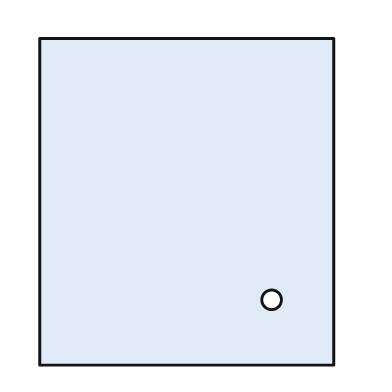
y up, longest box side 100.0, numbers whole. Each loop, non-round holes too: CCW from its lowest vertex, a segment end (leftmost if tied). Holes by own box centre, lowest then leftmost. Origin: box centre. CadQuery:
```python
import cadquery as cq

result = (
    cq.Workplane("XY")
    .moveTo(-45.0, -50.0)
    .lineTo(45.0, -50.0)
    .lineTo(45.0, 50.0)
    .lineTo(-45.0, 50.0)
    .close()
    .moveTo(26.0, -30.0)
    .circle(3.0)
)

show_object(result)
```